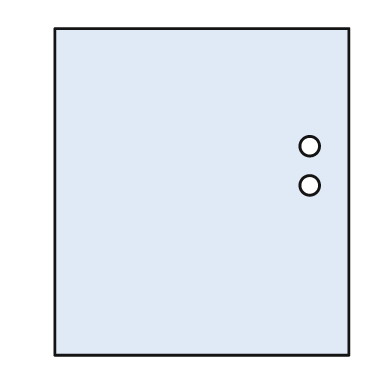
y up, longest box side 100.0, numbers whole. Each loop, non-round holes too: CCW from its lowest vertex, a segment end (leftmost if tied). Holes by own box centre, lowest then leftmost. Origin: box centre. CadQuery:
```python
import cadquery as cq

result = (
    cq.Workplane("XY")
    .moveTo(-45.0, -50.0)
    .lineTo(45.0, -50.0)
    .lineTo(45.0, 50.0)
    .lineTo(-45.0, 50.0)
    .close()
    .moveTo(33.0, 2.0)
    .circle(3.0)
    .moveTo(33.0, 14.0)
    .circle(3.0)
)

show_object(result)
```